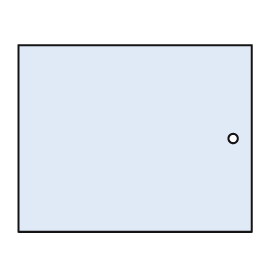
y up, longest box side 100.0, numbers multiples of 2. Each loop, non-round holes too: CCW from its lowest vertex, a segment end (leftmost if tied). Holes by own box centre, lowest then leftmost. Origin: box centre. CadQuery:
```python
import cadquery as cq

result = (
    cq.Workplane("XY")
    .moveTo(-50.0, -40.0)
    .lineTo(50.0, -40.0)
    .lineTo(50.0, 40.0)
    .lineTo(-50.0, 40.0)
    .close()
    .moveTo(42.0, 0.0)
    .circle(2.0)
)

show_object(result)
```